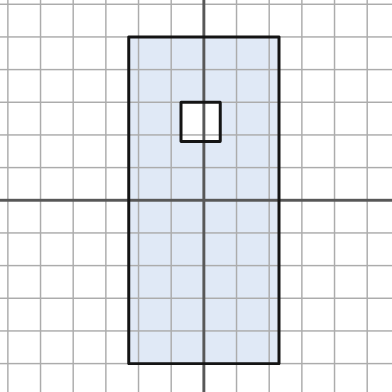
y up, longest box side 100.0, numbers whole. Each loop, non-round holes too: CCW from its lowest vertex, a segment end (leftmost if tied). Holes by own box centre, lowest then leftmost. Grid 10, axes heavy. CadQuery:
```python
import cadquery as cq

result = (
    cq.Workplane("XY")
    .moveTo(-23.0, -50.0)
    .lineTo(23.0, -50.0)
    .lineTo(23.0, 50.0)
    .lineTo(-23.0, 50.0)
    .close()
    .moveTo(-7.0, 18.0)
    .lineTo(5.0, 18.0)
    .lineTo(5.0, 30.0)
    .lineTo(-7.0, 30.0)
    .close()
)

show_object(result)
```